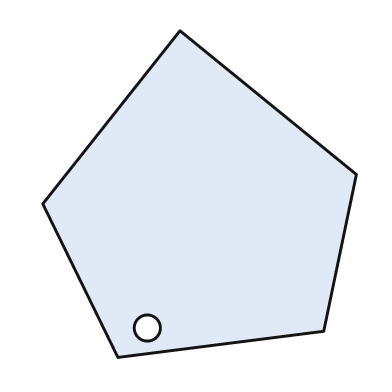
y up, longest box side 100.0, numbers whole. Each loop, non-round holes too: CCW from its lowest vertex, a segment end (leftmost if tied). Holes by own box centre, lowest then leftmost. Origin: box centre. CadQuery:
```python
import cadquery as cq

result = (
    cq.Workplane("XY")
    .moveTo(-25.0, -50.0)
    .lineTo(38.0, -42.0)
    .lineTo(48.0, 6.0)
    .lineTo(-6.0, 50.0)
    .lineTo(-48.0, -3.0)
    .close()
    .moveTo(-16.0, -41.0)
    .circle(4.0)
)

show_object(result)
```